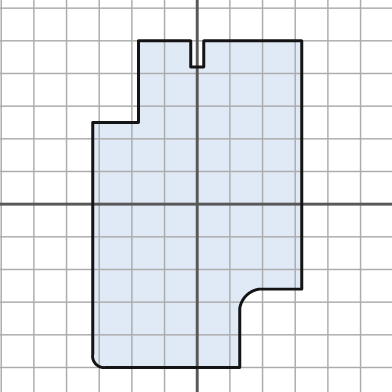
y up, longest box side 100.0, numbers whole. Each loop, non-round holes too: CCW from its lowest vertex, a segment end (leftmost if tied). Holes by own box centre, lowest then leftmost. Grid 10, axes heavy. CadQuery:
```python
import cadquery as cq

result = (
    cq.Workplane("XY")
    .moveTo(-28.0, -50.0)
    .lineTo(13.0, -50.0)
    .lineTo(13.0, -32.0)
    .threePointArc((15.0, -28.0), (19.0, -26.0))
    .lineTo(32.0, -26.0)
    .lineTo(32.0, 50.0)
    .lineTo(2.0, 50.0)
    .lineTo(2.0, 42.0)
    .lineTo(-2.0, 42.0)
    .lineTo(-2.0, 50.0)
    .lineTo(-18.0, 50.0)
    .lineTo(-18.0, 25.0)
    .lineTo(-32.0, 25.0)
    .lineTo(-32.0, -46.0)
    .threePointArc((-31.0, -49.0), (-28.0, -50.0))
    .close()
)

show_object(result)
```